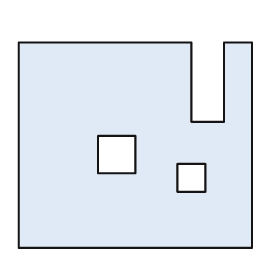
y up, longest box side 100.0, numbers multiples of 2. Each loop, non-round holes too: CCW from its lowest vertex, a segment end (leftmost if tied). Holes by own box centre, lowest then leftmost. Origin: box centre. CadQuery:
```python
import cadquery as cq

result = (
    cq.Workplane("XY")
    .moveTo(-50.0, -44.0)
    .lineTo(50.0, -44.0)
    .lineTo(50.0, 44.0)
    .lineTo(38.0, 44.0)
    .lineTo(38.0, 10.0)
    .lineTo(24.0, 10.0)
    .lineTo(24.0, 44.0)
    .lineTo(-50.0, 44.0)
    .close()
    .moveTo(18.0, -20.0)
    .lineTo(30.0, -20.0)
    .lineTo(30.0, -8.0)
    .lineTo(18.0, -8.0)
    .close()
    .moveTo(-16.0, -12.0)
    .lineTo(0.0, -12.0)
    .lineTo(0.0, 4.0)
    .lineTo(-16.0, 4.0)
    .close()
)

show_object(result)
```